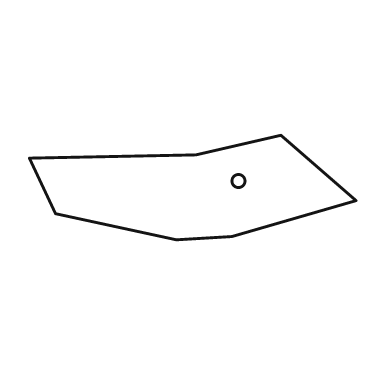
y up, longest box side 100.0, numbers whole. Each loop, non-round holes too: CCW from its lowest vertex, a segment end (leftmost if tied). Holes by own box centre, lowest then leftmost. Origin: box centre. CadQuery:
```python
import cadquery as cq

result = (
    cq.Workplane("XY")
    .moveTo(-5.0, -16.0)
    .lineTo(12.0, -15.0)
    .lineTo(50.0, -4.0)
    .lineTo(27.0, 16.0)
    .lineTo(1.0, 10.0)
    .lineTo(-50.0, 9.0)
    .lineTo(-42.0, -8.0)
    .close()
    .moveTo(14.0, 2.0)
    .circle(2.0)
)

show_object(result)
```